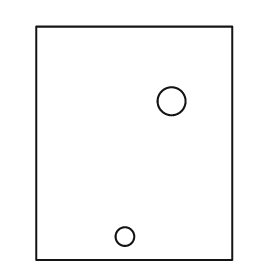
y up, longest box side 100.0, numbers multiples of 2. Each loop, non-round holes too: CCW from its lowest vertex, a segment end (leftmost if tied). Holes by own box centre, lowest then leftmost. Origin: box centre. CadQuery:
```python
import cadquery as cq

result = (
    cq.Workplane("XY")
    .moveTo(-42.0, -50.0)
    .lineTo(42.0, -50.0)
    .lineTo(42.0, 50.0)
    .lineTo(-42.0, 50.0)
    .close()
    .moveTo(-4.0, -40.0)
    .circle(4.0)
    .moveTo(16.0, 18.0)
    .circle(6.0)
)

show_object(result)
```